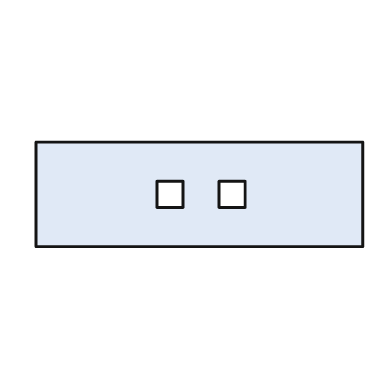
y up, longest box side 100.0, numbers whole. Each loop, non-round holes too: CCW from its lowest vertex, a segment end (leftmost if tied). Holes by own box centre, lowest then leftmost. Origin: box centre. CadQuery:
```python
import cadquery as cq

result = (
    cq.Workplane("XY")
    .moveTo(-50.0, -16.0)
    .lineTo(50.0, -16.0)
    .lineTo(50.0, 16.0)
    .lineTo(-50.0, 16.0)
    .close()
    .moveTo(-13.0, -4.0)
    .lineTo(-5.0, -4.0)
    .lineTo(-5.0, 4.0)
    .lineTo(-13.0, 4.0)
    .close()
    .moveTo(6.0, -4.0)
    .lineTo(14.0, -4.0)
    .lineTo(14.0, 4.0)
    .lineTo(6.0, 4.0)
    .close()
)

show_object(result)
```